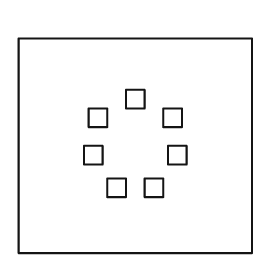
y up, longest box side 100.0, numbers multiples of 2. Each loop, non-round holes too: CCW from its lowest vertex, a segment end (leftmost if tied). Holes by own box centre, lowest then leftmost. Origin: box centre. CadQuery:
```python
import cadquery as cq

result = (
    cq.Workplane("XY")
    .moveTo(-50.0, -46.0)
    .lineTo(50.0, -46.0)
    .lineTo(50.0, 46.0)
    .lineTo(-50.0, 46.0)
    .close()
    .moveTo(-12.0, -22.0)
    .lineTo(-4.0, -22.0)
    .lineTo(-4.0, -14.0)
    .lineTo(-12.0, -14.0)
    .close()
    .moveTo(4.0, -22.0)
    .lineTo(12.0, -22.0)
    .lineTo(12.0, -14.0)
    .lineTo(4.0, -14.0)
    .close()
    .moveTo(-22.0, -8.0)
    .lineTo(-14.0, -8.0)
    .lineTo(-14.0, 0.0)
    .lineTo(-22.0, 0.0)
    .close()
    .moveTo(14.0, -8.0)
    .lineTo(22.0, -8.0)
    .lineTo(22.0, 0.0)
    .lineTo(14.0, 0.0)
    .close()
    .moveTo(-20.0, 8.0)
    .lineTo(-12.0, 8.0)
    .lineTo(-12.0, 16.0)
    .lineTo(-20.0, 16.0)
    .close()
    .moveTo(12.0, 8.0)
    .lineTo(20.0, 8.0)
    .lineTo(20.0, 16.0)
    .lineTo(12.0, 16.0)
    .close()
    .moveTo(-4.0, 16.0)
    .lineTo(4.0, 16.0)
    .lineTo(4.0, 24.0)
    .lineTo(-4.0, 24.0)
    .close()
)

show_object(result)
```